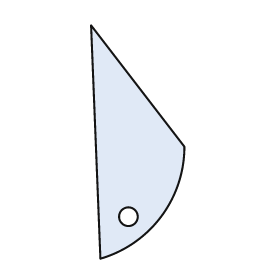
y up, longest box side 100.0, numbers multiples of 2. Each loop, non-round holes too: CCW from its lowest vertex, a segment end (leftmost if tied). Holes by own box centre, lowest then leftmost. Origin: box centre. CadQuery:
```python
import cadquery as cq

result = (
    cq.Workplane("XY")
    .moveTo(-16.0, -50.0)
    .threePointArc((10.0, -32.0), (20.0, -2.0))
    .lineTo(-20.0, 50.0)
    .close()
    .moveTo(-4.0, -32.0)
    .circle(4.0)
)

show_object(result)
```